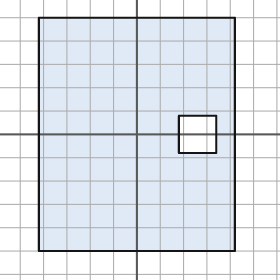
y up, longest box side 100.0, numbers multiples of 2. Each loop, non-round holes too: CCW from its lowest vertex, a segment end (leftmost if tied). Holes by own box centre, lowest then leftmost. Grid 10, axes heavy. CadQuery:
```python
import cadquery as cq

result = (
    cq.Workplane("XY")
    .moveTo(-42.0, -50.0)
    .lineTo(42.0, -50.0)
    .lineTo(42.0, 50.0)
    .lineTo(-42.0, 50.0)
    .close()
    .moveTo(18.0, -8.0)
    .lineTo(34.0, -8.0)
    .lineTo(34.0, 8.0)
    .lineTo(18.0, 8.0)
    .close()
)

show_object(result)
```